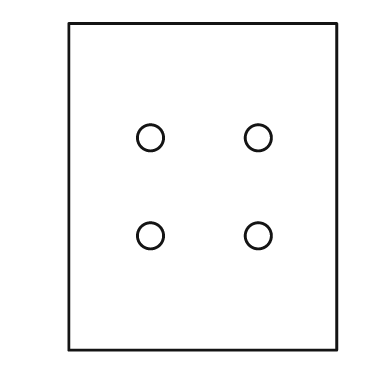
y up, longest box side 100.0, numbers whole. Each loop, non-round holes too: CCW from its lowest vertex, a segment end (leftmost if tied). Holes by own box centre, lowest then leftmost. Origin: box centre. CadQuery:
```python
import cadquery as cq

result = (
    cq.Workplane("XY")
    .moveTo(-41.0, -50.0)
    .lineTo(41.0, -50.0)
    .lineTo(41.0, 50.0)
    .lineTo(-41.0, 50.0)
    .close()
    .moveTo(-16.0, -15.0)
    .circle(4.0)
    .moveTo(17.0, -15.0)
    .circle(4.0)
    .moveTo(-16.0, 15.0)
    .circle(4.0)
    .moveTo(17.0, 15.0)
    .circle(4.0)
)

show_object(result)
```